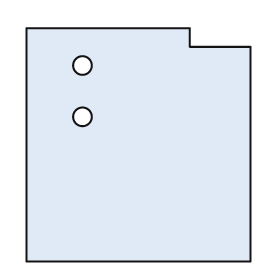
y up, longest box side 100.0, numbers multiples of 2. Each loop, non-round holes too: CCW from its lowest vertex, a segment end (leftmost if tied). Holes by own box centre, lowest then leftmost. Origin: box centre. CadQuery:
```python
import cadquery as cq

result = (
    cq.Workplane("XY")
    .moveTo(-48.0, -50.0)
    .lineTo(48.0, -50.0)
    .lineTo(48.0, 42.0)
    .lineTo(22.0, 42.0)
    .lineTo(22.0, 50.0)
    .lineTo(-48.0, 50.0)
    .close()
    .moveTo(-24.0, 12.0)
    .circle(4.0)
    .moveTo(-24.0, 34.0)
    .circle(4.0)
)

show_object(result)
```